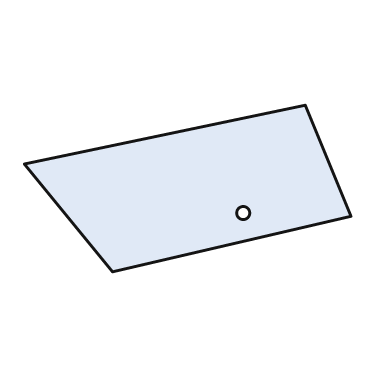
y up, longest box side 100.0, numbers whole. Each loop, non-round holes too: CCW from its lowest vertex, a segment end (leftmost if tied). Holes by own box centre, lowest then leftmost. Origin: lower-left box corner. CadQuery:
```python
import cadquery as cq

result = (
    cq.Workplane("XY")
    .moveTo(27.0, 0.0)
    .lineTo(100.0, 17.0)
    .lineTo(86.0, 51.0)
    .lineTo(0.0, 33.0)
    .close()
    .moveTo(67.0, 18.0)
    .circle(2.0)
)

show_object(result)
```